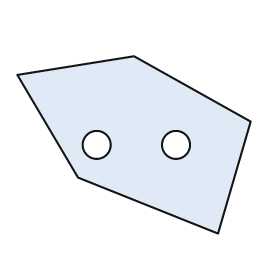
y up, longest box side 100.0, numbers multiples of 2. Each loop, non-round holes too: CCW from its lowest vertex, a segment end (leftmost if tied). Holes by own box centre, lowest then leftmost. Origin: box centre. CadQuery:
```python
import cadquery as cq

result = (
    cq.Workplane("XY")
    .moveTo(36.0, -38.0)
    .lineTo(50.0, 10.0)
    .lineTo(0.0, 38.0)
    .lineTo(-50.0, 30.0)
    .lineTo(-24.0, -14.0)
    .close()
    .moveTo(-16.0, 0.0)
    .circle(6.0)
    .moveTo(18.0, 0.0)
    .circle(6.0)
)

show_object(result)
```